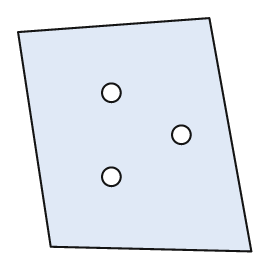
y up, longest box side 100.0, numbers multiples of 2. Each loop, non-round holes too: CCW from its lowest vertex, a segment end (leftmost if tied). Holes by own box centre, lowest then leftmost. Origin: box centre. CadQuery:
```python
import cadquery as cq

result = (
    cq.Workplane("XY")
    .moveTo(50.0, -50.0)
    .lineTo(32.0, 50.0)
    .lineTo(-50.0, 44.0)
    .lineTo(-36.0, -48.0)
    .close()
    .moveTo(-10.0, -18.0)
    .circle(4.0)
    .moveTo(20.0, 0.0)
    .circle(4.0)
    .moveTo(-10.0, 18.0)
    .circle(4.0)
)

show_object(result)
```